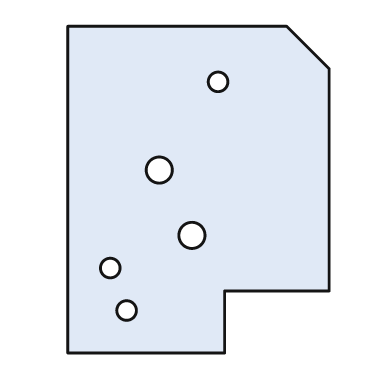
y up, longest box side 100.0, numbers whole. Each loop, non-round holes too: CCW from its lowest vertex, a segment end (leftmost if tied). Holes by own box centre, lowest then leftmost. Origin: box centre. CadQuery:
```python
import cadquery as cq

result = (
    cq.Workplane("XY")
    .moveTo(-40.0, -50.0)
    .lineTo(8.0, -50.0)
    .lineTo(8.0, -31.0)
    .lineTo(40.0, -31.0)
    .lineTo(40.0, 37.0)
    .lineTo(27.0, 50.0)
    .lineTo(-40.0, 50.0)
    .close()
    .moveTo(-22.0, -37.0)
    .circle(3.0)
    .moveTo(-27.0, -24.0)
    .circle(3.0)
    .moveTo(-2.0, -14.0)
    .circle(4.0)
    .moveTo(-12.0, 6.0)
    .circle(4.0)
    .moveTo(6.0, 33.0)
    .circle(3.0)
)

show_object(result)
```